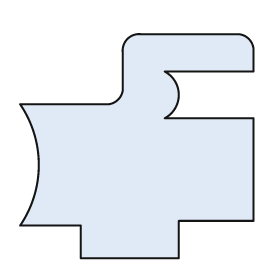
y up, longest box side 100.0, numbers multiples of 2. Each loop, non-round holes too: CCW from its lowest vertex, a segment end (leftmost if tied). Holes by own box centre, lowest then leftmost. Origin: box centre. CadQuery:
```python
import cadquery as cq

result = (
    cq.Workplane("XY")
    .moveTo(-24.0, -48.0)
    .lineTo(18.0, -48.0)
    .lineTo(18.0, -32.0)
    .lineTo(50.0, -32.0)
    .lineTo(50.0, 12.0)
    .lineTo(12.0, 12.0)
    .threePointArc((18.0, 22.0), (12.0, 32.0))
    .lineTo(50.0, 32.0)
    .lineTo(50.0, 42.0)
    .threePointArc((48.0, 46.0), (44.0, 48.0))
    .lineTo(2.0, 48.0)
    .threePointArc((-4.0, 46.0), (-6.0, 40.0))
    .lineTo(-6.0, 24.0)
    .threePointArc((-8.0, 20.0), (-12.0, 18.0))
    .lineTo(-50.0, 18.0)
    .threePointArc((-42.0, -8.0), (-50.0, -34.0))
    .lineTo(-24.0, -34.0)
    .close()
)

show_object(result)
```